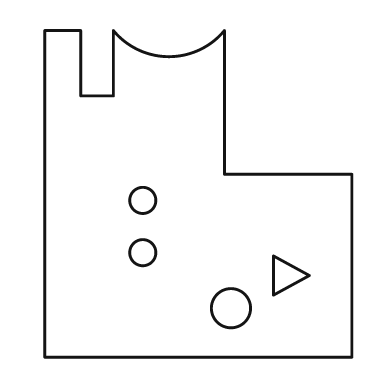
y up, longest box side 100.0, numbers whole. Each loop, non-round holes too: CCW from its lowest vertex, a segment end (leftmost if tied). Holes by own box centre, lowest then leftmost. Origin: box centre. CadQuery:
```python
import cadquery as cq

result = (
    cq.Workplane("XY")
    .moveTo(-47.0, -50.0)
    .lineTo(47.0, -50.0)
    .lineTo(47.0, 6.0)
    .lineTo(8.0, 6.0)
    .lineTo(8.0, 50.0)
    .threePointArc((-9.0, 42.0), (-26.0, 50.0))
    .lineTo(-26.0, 30.0)
    .lineTo(-36.0, 30.0)
    .lineTo(-36.0, 50.0)
    .lineTo(-47.0, 50.0)
    .close()
    .moveTo(10.0, -35.0)
    .circle(6.0)
    .moveTo(23.0, -31.0)
    .lineTo(34.0, -25.0)
    .lineTo(23.0, -19.0)
    .close()
    .moveTo(-17.0, -18.0)
    .circle(4.0)
    .moveTo(-17.0, -2.0)
    .circle(4.0)
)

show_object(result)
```